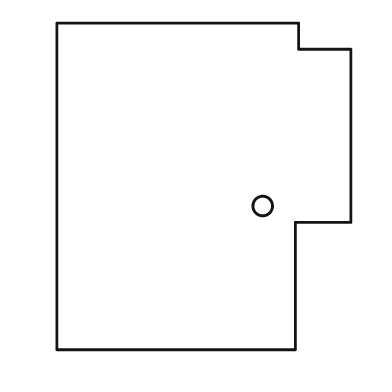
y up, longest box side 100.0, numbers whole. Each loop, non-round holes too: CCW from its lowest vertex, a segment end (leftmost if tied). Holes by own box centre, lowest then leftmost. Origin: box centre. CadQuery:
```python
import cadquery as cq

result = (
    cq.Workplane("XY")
    .moveTo(-45.0, -50.0)
    .lineTo(28.0, -50.0)
    .lineTo(28.0, -11.0)
    .lineTo(45.0, -11.0)
    .lineTo(45.0, 42.0)
    .lineTo(29.0, 42.0)
    .lineTo(29.0, 50.0)
    .lineTo(-45.0, 50.0)
    .close()
    .moveTo(18.0, -6.0)
    .circle(3.0)
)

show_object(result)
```